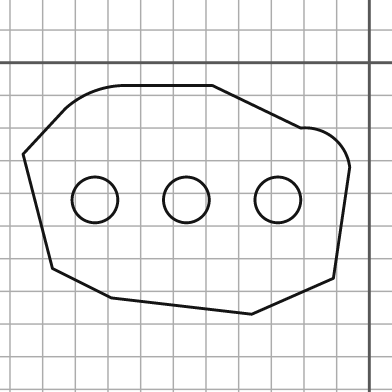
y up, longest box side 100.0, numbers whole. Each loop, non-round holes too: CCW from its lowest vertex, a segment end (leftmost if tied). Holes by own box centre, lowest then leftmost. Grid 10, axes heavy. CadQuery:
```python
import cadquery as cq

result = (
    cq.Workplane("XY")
    .moveTo(-36.0, -77.0)
    .lineTo(-11.0, -66.0)
    .lineTo(-6.0, -32.0)
    .threePointArc((-11.0, -23.0), (-21.0, -20.0))
    .lineTo(-48.0, -7.0)
    .lineTo(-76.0, -7.0)
    .threePointArc((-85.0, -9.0), (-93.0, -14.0))
    .lineTo(-106.0, -28.0)
    .lineTo(-97.0, -63.0)
    .lineTo(-79.0, -72.0)
    .close()
    .moveTo(-84.0, -42.0)
    .circle(7.0)
    .moveTo(-56.0, -42.0)
    .circle(7.0)
    .moveTo(-28.0, -42.0)
    .circle(7.0)
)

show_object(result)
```